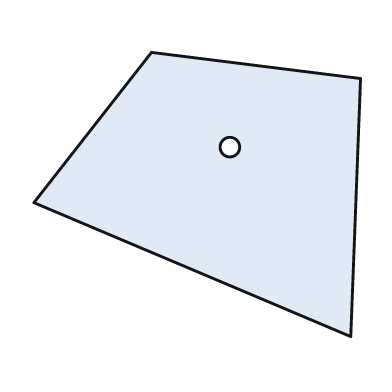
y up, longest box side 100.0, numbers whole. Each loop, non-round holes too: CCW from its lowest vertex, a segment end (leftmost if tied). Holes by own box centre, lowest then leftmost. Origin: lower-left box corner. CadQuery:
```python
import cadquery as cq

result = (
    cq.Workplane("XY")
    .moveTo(97.0, 0.0)
    .lineTo(100.0, 79.0)
    .lineTo(36.0, 87.0)
    .lineTo(0.0, 41.0)
    .close()
    .moveTo(60.0, 58.0)
    .circle(3.0)
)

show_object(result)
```